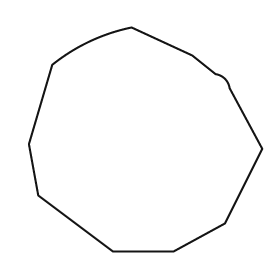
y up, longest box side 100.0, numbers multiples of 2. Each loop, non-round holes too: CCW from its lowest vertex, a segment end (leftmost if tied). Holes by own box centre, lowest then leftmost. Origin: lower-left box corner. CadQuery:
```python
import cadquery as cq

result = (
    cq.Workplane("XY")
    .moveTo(36.0, 0.0)
    .lineTo(62.0, 0.0)
    .lineTo(84.0, 12.0)
    .lineTo(100.0, 44.0)
    .lineTo(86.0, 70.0)
    .threePointArc((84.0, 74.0), (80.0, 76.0))
    .lineTo(70.0, 84.0)
    .lineTo(44.0, 96.0)
    .threePointArc((26.0, 90.0), (10.0, 80.0))
    .lineTo(0.0, 46.0)
    .lineTo(4.0, 24.0)
    .close()
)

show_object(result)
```